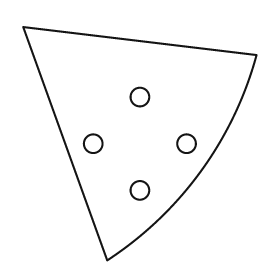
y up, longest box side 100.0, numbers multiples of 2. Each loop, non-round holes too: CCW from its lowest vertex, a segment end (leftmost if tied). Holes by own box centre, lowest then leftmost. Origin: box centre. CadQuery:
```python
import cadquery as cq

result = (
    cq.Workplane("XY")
    .moveTo(-14.0, -50.0)
    .threePointArc((26.0, -12.0), (50.0, 38.0))
    .lineTo(-50.0, 50.0)
    .close()
    .moveTo(0.0, -20.0)
    .circle(4.0)
    .moveTo(-20.0, 0.0)
    .circle(4.0)
    .moveTo(20.0, 0.0)
    .circle(4.0)
    .moveTo(0.0, 20.0)
    .circle(4.0)
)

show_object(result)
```